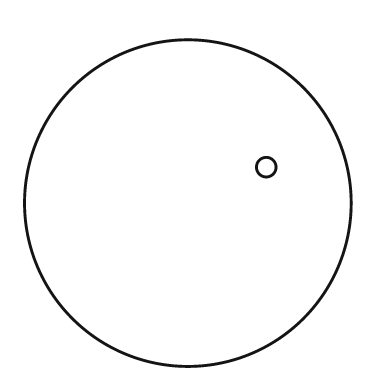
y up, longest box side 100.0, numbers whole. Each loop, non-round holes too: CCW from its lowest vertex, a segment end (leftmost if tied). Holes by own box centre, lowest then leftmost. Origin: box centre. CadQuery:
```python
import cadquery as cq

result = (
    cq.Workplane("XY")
    .moveTo(0.0, 0.0)
    .circle(50.0)
    .moveTo(24.0, 11.0)
    .circle(3.0)
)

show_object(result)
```